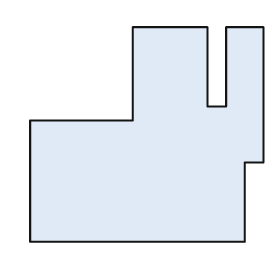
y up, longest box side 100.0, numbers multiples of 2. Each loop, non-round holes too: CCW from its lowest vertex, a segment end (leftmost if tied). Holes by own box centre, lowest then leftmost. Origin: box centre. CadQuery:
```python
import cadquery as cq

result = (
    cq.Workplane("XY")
    .moveTo(-50.0, -46.0)
    .lineTo(42.0, -46.0)
    .lineTo(42.0, -12.0)
    .lineTo(50.0, -12.0)
    .lineTo(50.0, 46.0)
    .lineTo(34.0, 46.0)
    .lineTo(34.0, 12.0)
    .lineTo(26.0, 12.0)
    .lineTo(26.0, 46.0)
    .lineTo(-6.0, 46.0)
    .lineTo(-6.0, 6.0)
    .lineTo(-50.0, 6.0)
    .close()
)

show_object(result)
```